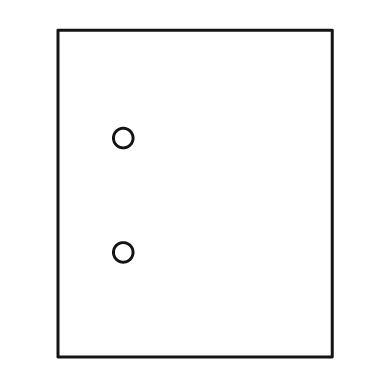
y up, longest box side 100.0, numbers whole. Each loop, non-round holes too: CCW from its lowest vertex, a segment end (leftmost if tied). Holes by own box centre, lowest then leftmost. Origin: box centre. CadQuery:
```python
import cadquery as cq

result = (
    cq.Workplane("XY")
    .moveTo(-42.0, -50.0)
    .lineTo(42.0, -50.0)
    .lineTo(42.0, 50.0)
    .lineTo(-42.0, 50.0)
    .close()
    .moveTo(-22.0, -18.0)
    .circle(3.0)
    .moveTo(-22.0, 17.0)
    .circle(3.0)
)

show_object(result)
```